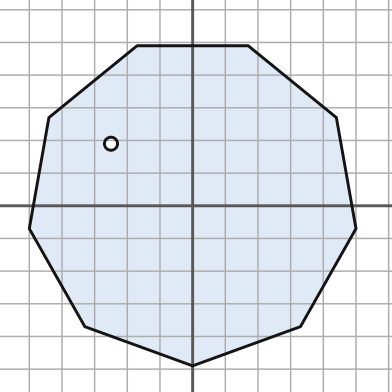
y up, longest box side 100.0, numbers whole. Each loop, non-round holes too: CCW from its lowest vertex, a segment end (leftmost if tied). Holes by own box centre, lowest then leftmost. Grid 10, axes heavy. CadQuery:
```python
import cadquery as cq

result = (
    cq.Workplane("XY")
    .moveTo(0.0, -49.0)
    .lineTo(33.0, -37.0)
    .lineTo(50.0, -7.0)
    .lineTo(44.0, 27.0)
    .lineTo(17.0, 49.0)
    .lineTo(-17.0, 49.0)
    .lineTo(-44.0, 27.0)
    .lineTo(-50.0, -7.0)
    .lineTo(-33.0, -37.0)
    .close()
    .moveTo(-25.0, 19.0)
    .circle(2.0)
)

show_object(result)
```